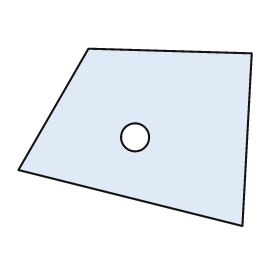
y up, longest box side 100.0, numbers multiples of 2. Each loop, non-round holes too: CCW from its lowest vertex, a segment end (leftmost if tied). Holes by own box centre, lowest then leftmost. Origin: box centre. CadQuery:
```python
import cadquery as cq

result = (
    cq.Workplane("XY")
    .moveTo(46.0, -38.0)
    .lineTo(50.0, 36.0)
    .lineTo(-20.0, 38.0)
    .lineTo(-50.0, -14.0)
    .close()
    .moveTo(0.0, 0.0)
    .circle(6.0)
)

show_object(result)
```